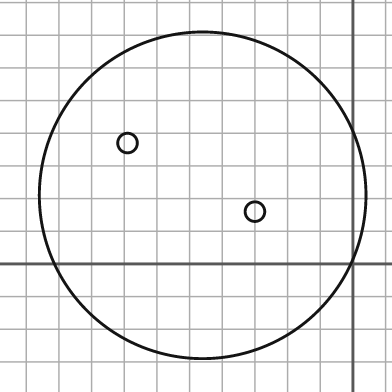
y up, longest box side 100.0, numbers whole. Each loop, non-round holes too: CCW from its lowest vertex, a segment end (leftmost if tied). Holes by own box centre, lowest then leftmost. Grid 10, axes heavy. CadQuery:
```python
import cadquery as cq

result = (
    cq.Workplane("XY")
    .moveTo(-46.0, 21.0)
    .circle(50.0)
    .moveTo(-30.0, 16.0)
    .circle(3.0)
    .moveTo(-69.0, 37.0)
    .circle(3.0)
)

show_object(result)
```